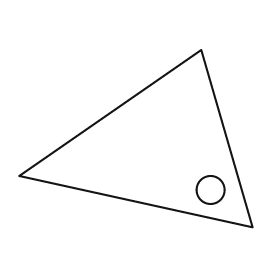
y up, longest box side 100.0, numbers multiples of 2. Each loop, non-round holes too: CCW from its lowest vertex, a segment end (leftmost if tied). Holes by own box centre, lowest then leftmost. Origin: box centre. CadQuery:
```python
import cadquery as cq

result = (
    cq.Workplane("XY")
    .moveTo(50.0, -38.0)
    .lineTo(28.0, 38.0)
    .lineTo(-50.0, -16.0)
    .close()
    .moveTo(32.0, -22.0)
    .circle(6.0)
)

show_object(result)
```